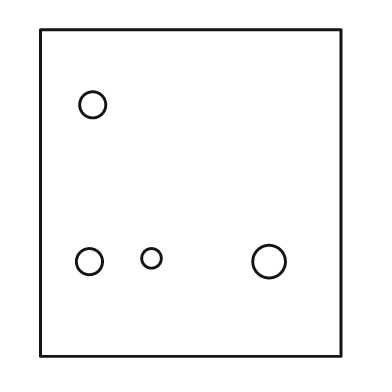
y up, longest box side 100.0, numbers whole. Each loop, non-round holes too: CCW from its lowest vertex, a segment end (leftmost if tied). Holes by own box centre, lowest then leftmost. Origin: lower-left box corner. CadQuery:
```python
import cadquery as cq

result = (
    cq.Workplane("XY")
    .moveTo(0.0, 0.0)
    .lineTo(92.0, 0.0)
    .lineTo(92.0, 100.0)
    .lineTo(0.0, 100.0)
    .close()
    .moveTo(15.0, 29.0)
    .circle(4.0)
    .moveTo(70.0, 29.0)
    .circle(5.0)
    .moveTo(34.0, 30.0)
    .circle(3.0)
    .moveTo(16.0, 77.0)
    .circle(4.0)
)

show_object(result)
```